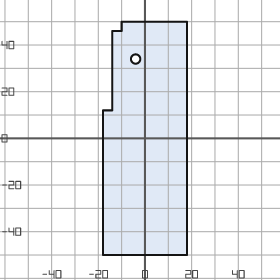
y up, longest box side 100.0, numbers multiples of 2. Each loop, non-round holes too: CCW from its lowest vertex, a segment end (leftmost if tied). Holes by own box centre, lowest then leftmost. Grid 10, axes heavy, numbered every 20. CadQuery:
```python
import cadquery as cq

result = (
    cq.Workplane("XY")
    .moveTo(-18.0, -50.0)
    .lineTo(18.0, -50.0)
    .lineTo(18.0, 50.0)
    .lineTo(-10.0, 50.0)
    .lineTo(-10.0, 46.0)
    .lineTo(-14.0, 46.0)
    .lineTo(-14.0, 12.0)
    .lineTo(-18.0, 12.0)
    .close()
    .moveTo(-4.0, 34.0)
    .circle(2.0)
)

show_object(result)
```